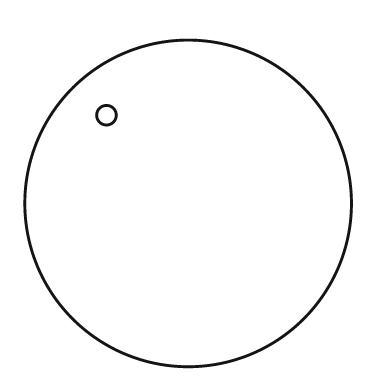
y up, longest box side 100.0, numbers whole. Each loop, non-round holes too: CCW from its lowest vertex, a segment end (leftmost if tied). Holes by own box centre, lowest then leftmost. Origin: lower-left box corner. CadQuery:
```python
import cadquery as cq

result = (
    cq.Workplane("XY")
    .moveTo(50.0, 50.0)
    .circle(50.0)
    .moveTo(25.0, 77.0)
    .circle(3.0)
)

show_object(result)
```